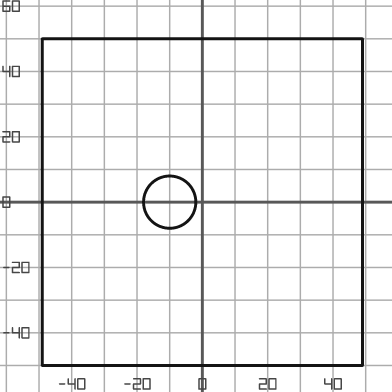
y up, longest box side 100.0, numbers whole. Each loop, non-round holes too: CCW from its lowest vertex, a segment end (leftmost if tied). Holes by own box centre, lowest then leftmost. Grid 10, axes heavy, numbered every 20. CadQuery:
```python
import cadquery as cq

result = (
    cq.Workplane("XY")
    .moveTo(-49.0, -50.0)
    .lineTo(49.0, -50.0)
    .lineTo(49.0, 50.0)
    .lineTo(-49.0, 50.0)
    .close()
    .moveTo(-10.0, 0.0)
    .circle(8.0)
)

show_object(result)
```